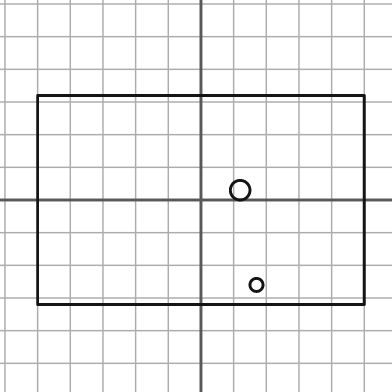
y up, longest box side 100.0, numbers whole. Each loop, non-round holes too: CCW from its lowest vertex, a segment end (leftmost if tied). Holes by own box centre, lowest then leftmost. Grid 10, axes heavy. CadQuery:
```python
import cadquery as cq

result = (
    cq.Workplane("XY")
    .moveTo(-50.0, -32.0)
    .lineTo(50.0, -32.0)
    .lineTo(50.0, 32.0)
    .lineTo(-50.0, 32.0)
    .close()
    .moveTo(17.0, -26.0)
    .circle(2.0)
    .moveTo(12.0, 3.0)
    .circle(3.0)
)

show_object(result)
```